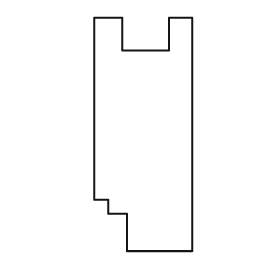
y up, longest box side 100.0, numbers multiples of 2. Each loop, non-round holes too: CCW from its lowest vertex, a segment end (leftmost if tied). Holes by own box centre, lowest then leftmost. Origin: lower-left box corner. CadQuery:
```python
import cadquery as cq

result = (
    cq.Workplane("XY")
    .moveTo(14.0, 0.0)
    .lineTo(42.0, 0.0)
    .lineTo(42.0, 100.0)
    .lineTo(32.0, 100.0)
    .lineTo(32.0, 86.0)
    .lineTo(12.0, 86.0)
    .lineTo(12.0, 100.0)
    .lineTo(0.0, 100.0)
    .lineTo(0.0, 22.0)
    .lineTo(6.0, 22.0)
    .lineTo(6.0, 16.0)
    .lineTo(14.0, 16.0)
    .close()
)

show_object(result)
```